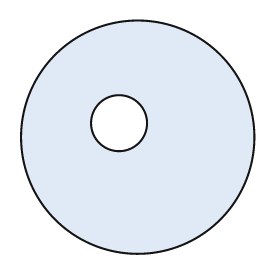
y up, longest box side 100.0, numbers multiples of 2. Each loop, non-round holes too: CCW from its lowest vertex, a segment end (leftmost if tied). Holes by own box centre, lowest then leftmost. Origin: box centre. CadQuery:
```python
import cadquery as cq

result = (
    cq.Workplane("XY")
    .moveTo(0.0, 0.0)
    .circle(50.0)
    .moveTo(-8.0, 6.0)
    .circle(12.0)
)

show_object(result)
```